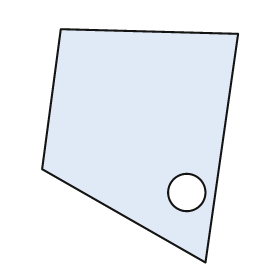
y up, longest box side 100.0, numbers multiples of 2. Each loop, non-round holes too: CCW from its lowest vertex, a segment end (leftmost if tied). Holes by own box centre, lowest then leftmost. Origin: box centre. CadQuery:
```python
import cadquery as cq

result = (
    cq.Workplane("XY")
    .moveTo(28.0, -50.0)
    .lineTo(42.0, 48.0)
    .lineTo(-34.0, 50.0)
    .lineTo(-42.0, -10.0)
    .close()
    .moveTo(20.0, -20.0)
    .circle(8.0)
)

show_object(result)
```